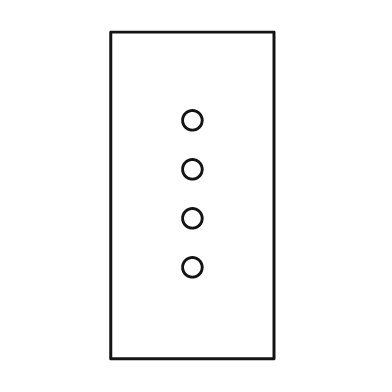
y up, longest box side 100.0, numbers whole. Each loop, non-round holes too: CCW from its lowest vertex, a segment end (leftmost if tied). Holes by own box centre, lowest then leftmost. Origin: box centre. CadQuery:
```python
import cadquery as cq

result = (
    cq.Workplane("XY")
    .moveTo(-25.0, -50.0)
    .lineTo(25.0, -50.0)
    .lineTo(25.0, 50.0)
    .lineTo(-25.0, 50.0)
    .close()
    .moveTo(0.0, -22.0)
    .circle(3.0)
    .moveTo(0.0, -7.0)
    .circle(3.0)
    .moveTo(0.0, 8.0)
    .circle(3.0)
    .moveTo(0.0, 23.0)
    .circle(3.0)
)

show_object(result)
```